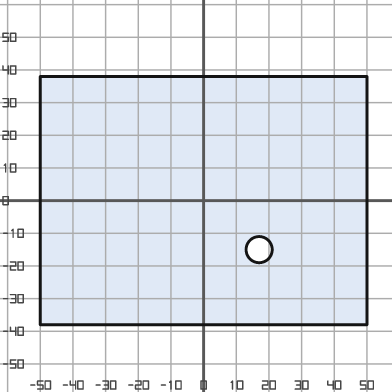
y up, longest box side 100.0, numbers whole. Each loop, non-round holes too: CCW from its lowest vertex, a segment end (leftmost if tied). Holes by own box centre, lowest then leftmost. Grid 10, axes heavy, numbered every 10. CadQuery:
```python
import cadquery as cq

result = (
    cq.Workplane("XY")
    .moveTo(-50.0, -38.0)
    .lineTo(50.0, -38.0)
    .lineTo(50.0, 38.0)
    .lineTo(-50.0, 38.0)
    .close()
    .moveTo(17.0, -15.0)
    .circle(4.0)
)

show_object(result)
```